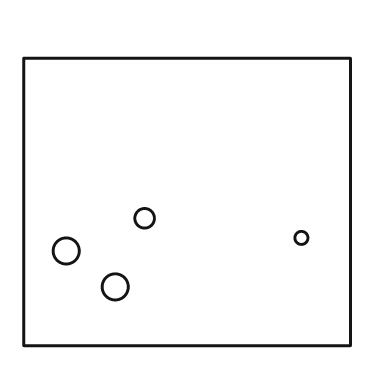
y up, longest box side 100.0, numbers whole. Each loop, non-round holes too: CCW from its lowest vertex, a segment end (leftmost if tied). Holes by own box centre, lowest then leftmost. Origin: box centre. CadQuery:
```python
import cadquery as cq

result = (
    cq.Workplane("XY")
    .moveTo(-50.0, -44.0)
    .lineTo(50.0, -44.0)
    .lineTo(50.0, 44.0)
    .lineTo(-50.0, 44.0)
    .close()
    .moveTo(-22.0, -26.0)
    .circle(4.0)
    .moveTo(-37.0, -15.0)
    .circle(4.0)
    .moveTo(35.0, -11.0)
    .circle(2.0)
    .moveTo(-13.0, -5.0)
    .circle(3.0)
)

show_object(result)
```